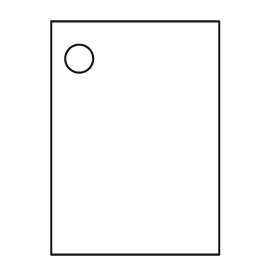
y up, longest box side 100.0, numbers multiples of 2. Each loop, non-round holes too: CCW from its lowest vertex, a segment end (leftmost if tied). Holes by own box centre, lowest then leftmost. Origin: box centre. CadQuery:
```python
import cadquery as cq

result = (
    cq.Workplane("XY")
    .moveTo(-36.0, -50.0)
    .lineTo(36.0, -50.0)
    .lineTo(36.0, 50.0)
    .lineTo(-36.0, 50.0)
    .close()
    .moveTo(-24.0, 34.0)
    .circle(6.0)
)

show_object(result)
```